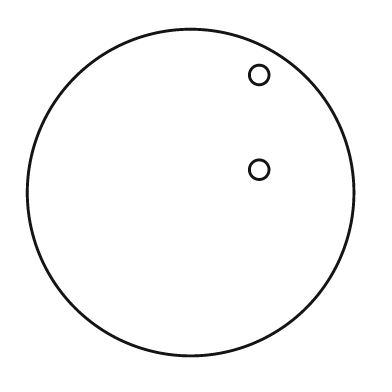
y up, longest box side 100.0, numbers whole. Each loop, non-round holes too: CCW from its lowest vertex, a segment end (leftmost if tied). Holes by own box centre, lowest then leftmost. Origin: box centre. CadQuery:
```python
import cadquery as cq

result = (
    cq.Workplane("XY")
    .moveTo(0.0, 0.0)
    .circle(50.0)
    .moveTo(21.0, 7.0)
    .circle(3.0)
    .moveTo(21.0, 36.0)
    .circle(3.0)
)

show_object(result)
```